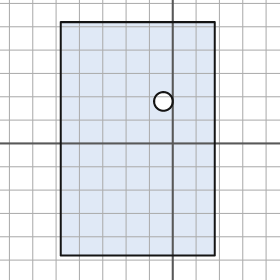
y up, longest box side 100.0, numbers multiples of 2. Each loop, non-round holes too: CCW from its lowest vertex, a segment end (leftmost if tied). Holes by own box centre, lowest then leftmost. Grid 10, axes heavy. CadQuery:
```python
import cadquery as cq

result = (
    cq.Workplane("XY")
    .moveTo(-48.0, -48.0)
    .lineTo(18.0, -48.0)
    .lineTo(18.0, 52.0)
    .lineTo(-48.0, 52.0)
    .close()
    .moveTo(-4.0, 18.0)
    .circle(4.0)
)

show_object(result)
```